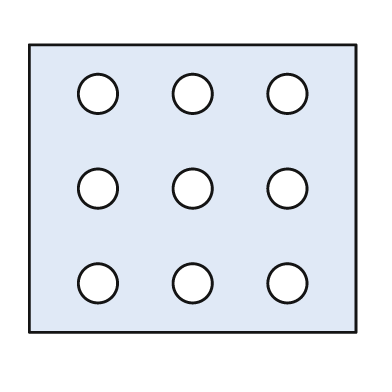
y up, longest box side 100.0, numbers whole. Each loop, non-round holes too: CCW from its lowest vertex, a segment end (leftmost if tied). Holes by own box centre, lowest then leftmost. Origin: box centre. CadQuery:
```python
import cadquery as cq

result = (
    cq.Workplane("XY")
    .moveTo(-50.0, -44.0)
    .lineTo(50.0, -44.0)
    .lineTo(50.0, 44.0)
    .lineTo(-50.0, 44.0)
    .close()
    .moveTo(-29.0, -29.0)
    .circle(6.0)
    .moveTo(0.0, -29.0)
    .circle(6.0)
    .moveTo(29.0, -29.0)
    .circle(6.0)
    .moveTo(-29.0, 0.0)
    .circle(6.0)
    .moveTo(0.0, 0.0)
    .circle(6.0)
    .moveTo(29.0, 0.0)
    .circle(6.0)
    .moveTo(-29.0, 29.0)
    .circle(6.0)
    .moveTo(0.0, 29.0)
    .circle(6.0)
    .moveTo(29.0, 29.0)
    .circle(6.0)
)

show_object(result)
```